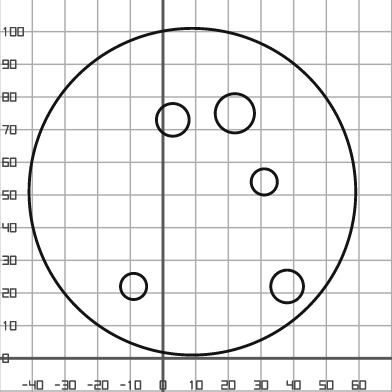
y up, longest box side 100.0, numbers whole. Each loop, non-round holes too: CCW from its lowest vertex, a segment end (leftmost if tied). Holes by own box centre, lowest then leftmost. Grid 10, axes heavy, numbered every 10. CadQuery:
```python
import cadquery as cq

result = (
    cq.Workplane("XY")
    .moveTo(9.0, 51.0)
    .circle(50.0)
    .moveTo(-9.0, 22.0)
    .circle(4.0)
    .moveTo(38.0, 22.0)
    .circle(5.0)
    .moveTo(31.0, 54.0)
    .circle(4.0)
    .moveTo(3.0, 73.0)
    .circle(5.0)
    .moveTo(22.0, 75.0)
    .circle(6.0)
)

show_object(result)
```